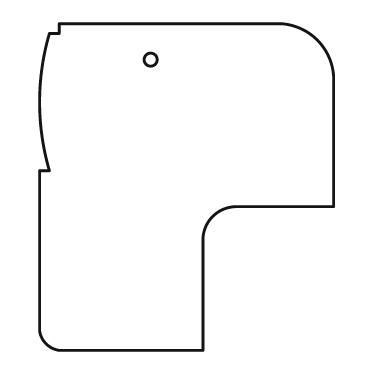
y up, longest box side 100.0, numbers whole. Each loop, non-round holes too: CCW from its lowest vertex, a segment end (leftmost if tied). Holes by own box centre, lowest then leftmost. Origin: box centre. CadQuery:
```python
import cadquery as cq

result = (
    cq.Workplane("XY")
    .moveTo(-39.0, -50.0)
    .lineTo(5.0, -50.0)
    .lineTo(5.0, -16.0)
    .threePointArc((8.0, -9.0), (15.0, -6.0))
    .lineTo(45.0, -6.0)
    .lineTo(45.0, 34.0)
    .threePointArc((40.0, 45.0), (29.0, 50.0))
    .lineTo(-39.0, 50.0)
    .lineTo(-39.0, 47.0)
    .lineTo(-42.0, 47.0)
    .threePointArc((-45.0, 26.0), (-42.0, 5.0))
    .lineTo(-45.0, 5.0)
    .lineTo(-45.0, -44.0)
    .threePointArc((-43.0, -48.0), (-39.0, -50.0))
    .close()
    .moveTo(-11.0, 39.0)
    .circle(2.0)
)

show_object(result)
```